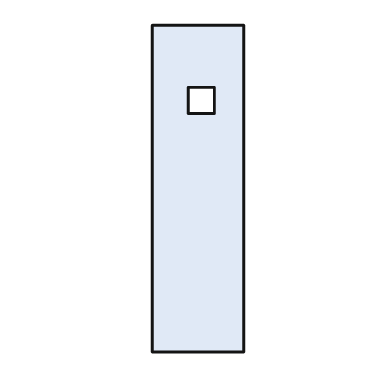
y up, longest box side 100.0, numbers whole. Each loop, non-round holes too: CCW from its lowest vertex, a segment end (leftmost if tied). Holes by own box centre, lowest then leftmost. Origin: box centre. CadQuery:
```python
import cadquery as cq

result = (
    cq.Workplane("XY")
    .moveTo(-14.0, -50.0)
    .lineTo(14.0, -50.0)
    .lineTo(14.0, 50.0)
    .lineTo(-14.0, 50.0)
    .close()
    .moveTo(-3.0, 23.0)
    .lineTo(5.0, 23.0)
    .lineTo(5.0, 31.0)
    .lineTo(-3.0, 31.0)
    .close()
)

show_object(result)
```